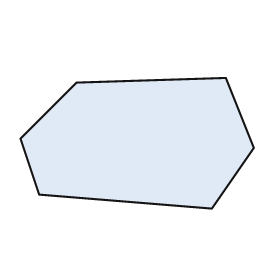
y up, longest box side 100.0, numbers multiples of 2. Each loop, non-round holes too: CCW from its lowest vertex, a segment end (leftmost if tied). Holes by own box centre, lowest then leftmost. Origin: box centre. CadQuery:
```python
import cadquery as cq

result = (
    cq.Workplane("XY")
    .moveTo(32.0, -28.0)
    .lineTo(50.0, -2.0)
    .lineTo(38.0, 28.0)
    .lineTo(-26.0, 26.0)
    .lineTo(-50.0, 2.0)
    .lineTo(-42.0, -22.0)
    .close()
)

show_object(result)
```